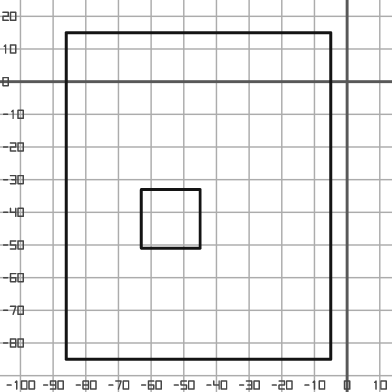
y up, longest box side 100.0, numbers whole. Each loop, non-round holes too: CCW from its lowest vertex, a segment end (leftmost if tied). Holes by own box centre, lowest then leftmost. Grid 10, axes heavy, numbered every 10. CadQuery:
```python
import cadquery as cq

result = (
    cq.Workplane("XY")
    .moveTo(-86.0, -85.0)
    .lineTo(-5.0, -85.0)
    .lineTo(-5.0, 15.0)
    .lineTo(-86.0, 15.0)
    .close()
    .moveTo(-63.0, -51.0)
    .lineTo(-45.0, -51.0)
    .lineTo(-45.0, -33.0)
    .lineTo(-63.0, -33.0)
    .close()
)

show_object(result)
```